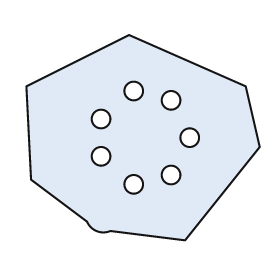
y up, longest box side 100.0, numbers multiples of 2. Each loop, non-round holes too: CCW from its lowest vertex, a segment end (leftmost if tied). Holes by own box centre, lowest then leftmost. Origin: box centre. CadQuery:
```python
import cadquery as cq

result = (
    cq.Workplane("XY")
    .moveTo(18.0, -44.0)
    .lineTo(50.0, -4.0)
    .lineTo(44.0, 22.0)
    .lineTo(-6.0, 44.0)
    .lineTo(-50.0, 22.0)
    .lineTo(-48.0, -18.0)
    .lineTo(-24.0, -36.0)
    .threePointArc((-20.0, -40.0), (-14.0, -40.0))
    .close()
    .moveTo(-4.0, -20.0)
    .circle(4.0)
    .moveTo(12.0, -16.0)
    .circle(4.0)
    .moveTo(-18.0, -8.0)
    .circle(4.0)
    .moveTo(20.0, 0.0)
    .circle(4.0)
    .moveTo(-18.0, 8.0)
    .circle(4.0)
    .moveTo(12.0, 16.0)
    .circle(4.0)
    .moveTo(-4.0, 20.0)
    .circle(4.0)
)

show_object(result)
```